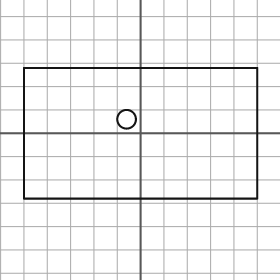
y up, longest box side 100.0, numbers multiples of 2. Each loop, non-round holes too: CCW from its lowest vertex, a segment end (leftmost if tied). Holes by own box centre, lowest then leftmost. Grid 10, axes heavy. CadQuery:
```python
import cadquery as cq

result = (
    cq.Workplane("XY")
    .moveTo(-50.0, -28.0)
    .lineTo(50.0, -28.0)
    .lineTo(50.0, 28.0)
    .lineTo(-50.0, 28.0)
    .close()
    .moveTo(-6.0, 6.0)
    .circle(4.0)
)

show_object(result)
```